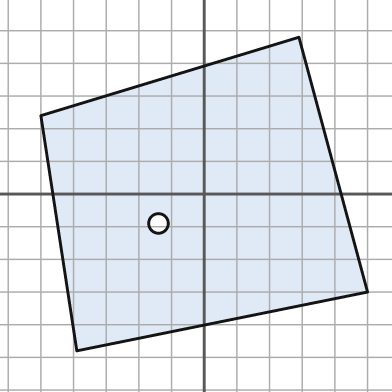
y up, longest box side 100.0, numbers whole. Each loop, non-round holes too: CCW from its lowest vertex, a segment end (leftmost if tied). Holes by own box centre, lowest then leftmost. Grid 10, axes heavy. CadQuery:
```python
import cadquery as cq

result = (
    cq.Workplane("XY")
    .moveTo(-39.0, -48.0)
    .lineTo(50.0, -30.0)
    .lineTo(29.0, 48.0)
    .lineTo(-50.0, 24.0)
    .close()
    .moveTo(-14.0, -9.0)
    .circle(3.0)
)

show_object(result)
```